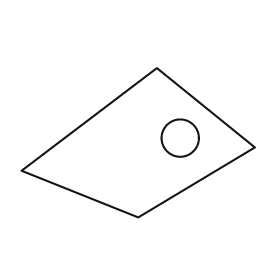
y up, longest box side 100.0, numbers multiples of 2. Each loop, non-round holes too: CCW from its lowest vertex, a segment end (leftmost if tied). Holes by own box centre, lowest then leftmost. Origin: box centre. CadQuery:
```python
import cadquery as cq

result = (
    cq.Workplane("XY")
    .moveTo(0.0, -32.0)
    .lineTo(50.0, -2.0)
    .lineTo(8.0, 32.0)
    .lineTo(-50.0, -12.0)
    .close()
    .moveTo(18.0, 2.0)
    .circle(8.0)
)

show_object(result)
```